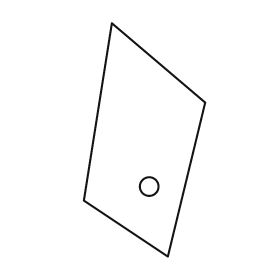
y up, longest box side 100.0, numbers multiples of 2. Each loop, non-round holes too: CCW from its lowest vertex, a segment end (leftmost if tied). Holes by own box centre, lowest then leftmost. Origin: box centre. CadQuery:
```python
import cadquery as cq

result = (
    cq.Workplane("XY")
    .moveTo(10.0, -50.0)
    .lineTo(26.0, 16.0)
    .lineTo(-14.0, 50.0)
    .lineTo(-26.0, -26.0)
    .close()
    .moveTo(2.0, -20.0)
    .circle(4.0)
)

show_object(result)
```